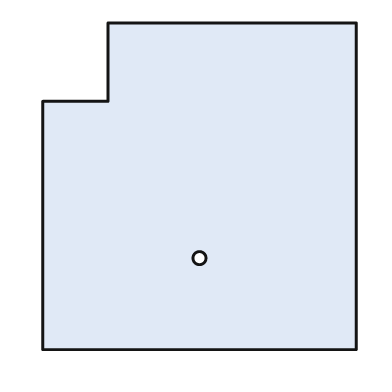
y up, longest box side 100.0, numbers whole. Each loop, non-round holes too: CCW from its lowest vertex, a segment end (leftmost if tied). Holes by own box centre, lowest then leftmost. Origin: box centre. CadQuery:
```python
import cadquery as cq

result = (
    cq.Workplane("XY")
    .moveTo(-48.0, -50.0)
    .lineTo(48.0, -50.0)
    .lineTo(48.0, 50.0)
    .lineTo(-28.0, 50.0)
    .lineTo(-28.0, 26.0)
    .lineTo(-48.0, 26.0)
    .close()
    .moveTo(0.0, -22.0)
    .circle(2.0)
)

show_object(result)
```